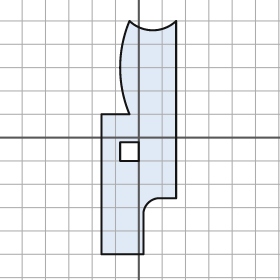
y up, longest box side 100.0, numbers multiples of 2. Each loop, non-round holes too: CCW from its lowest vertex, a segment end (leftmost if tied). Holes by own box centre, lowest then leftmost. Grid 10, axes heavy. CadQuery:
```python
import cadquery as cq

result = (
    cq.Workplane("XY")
    .moveTo(-16.0, -50.0)
    .lineTo(2.0, -50.0)
    .lineTo(2.0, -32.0)
    .threePointArc((4.0, -28.0), (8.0, -26.0))
    .lineTo(16.0, -26.0)
    .lineTo(16.0, 50.0)
    .threePointArc((6.0, 46.0), (-4.0, 50.0))
    .threePointArc((-8.0, 30.0), (-4.0, 10.0))
    .lineTo(-16.0, 10.0)
    .close()
    .moveTo(-8.0, -10.0)
    .lineTo(0.0, -10.0)
    .lineTo(0.0, -2.0)
    .lineTo(-8.0, -2.0)
    .close()
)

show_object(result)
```